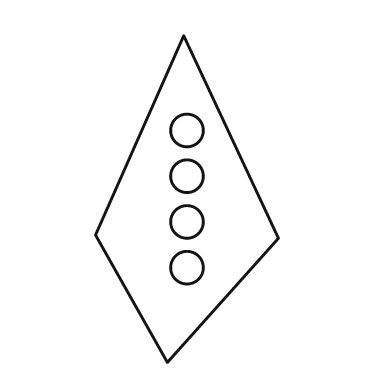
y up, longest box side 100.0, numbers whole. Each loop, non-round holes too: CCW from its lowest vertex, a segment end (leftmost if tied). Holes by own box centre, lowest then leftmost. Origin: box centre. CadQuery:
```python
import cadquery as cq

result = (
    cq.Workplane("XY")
    .moveTo(-6.0, -50.0)
    .lineTo(28.0, -12.0)
    .lineTo(-1.0, 50.0)
    .lineTo(-28.0, -11.0)
    .close()
    .moveTo(0.0, -21.0)
    .circle(5.0)
    .moveTo(0.0, -7.0)
    .circle(5.0)
    .moveTo(0.0, 7.0)
    .circle(5.0)
    .moveTo(0.0, 21.0)
    .circle(5.0)
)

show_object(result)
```